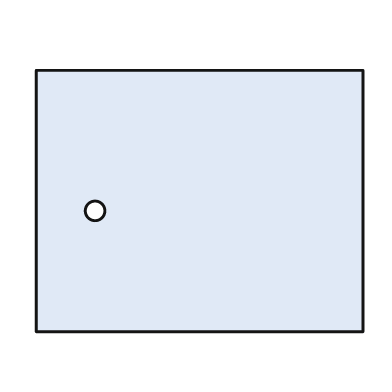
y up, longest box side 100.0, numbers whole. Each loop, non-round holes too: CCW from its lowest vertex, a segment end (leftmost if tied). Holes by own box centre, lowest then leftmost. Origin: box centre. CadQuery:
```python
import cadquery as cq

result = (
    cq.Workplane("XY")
    .moveTo(-50.0, -40.0)
    .lineTo(50.0, -40.0)
    .lineTo(50.0, 40.0)
    .lineTo(-50.0, 40.0)
    .close()
    .moveTo(-32.0, -3.0)
    .circle(3.0)
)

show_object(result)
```